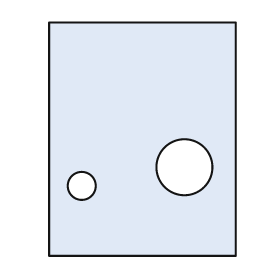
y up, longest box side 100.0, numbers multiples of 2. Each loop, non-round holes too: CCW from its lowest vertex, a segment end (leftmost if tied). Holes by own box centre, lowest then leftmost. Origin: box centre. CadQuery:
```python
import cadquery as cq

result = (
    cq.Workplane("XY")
    .moveTo(-40.0, -50.0)
    .lineTo(40.0, -50.0)
    .lineTo(40.0, 50.0)
    .lineTo(-40.0, 50.0)
    .close()
    .moveTo(-26.0, -20.0)
    .circle(6.0)
    .moveTo(18.0, -12.0)
    .circle(12.0)
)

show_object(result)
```